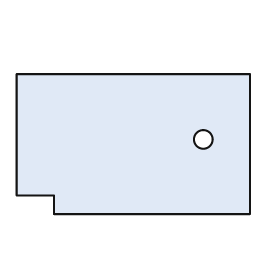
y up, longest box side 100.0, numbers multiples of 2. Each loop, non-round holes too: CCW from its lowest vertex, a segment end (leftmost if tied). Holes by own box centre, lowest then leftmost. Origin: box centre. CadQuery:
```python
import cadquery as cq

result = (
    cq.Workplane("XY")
    .moveTo(-34.0, -30.0)
    .lineTo(50.0, -30.0)
    .lineTo(50.0, 30.0)
    .lineTo(-50.0, 30.0)
    .lineTo(-50.0, -22.0)
    .lineTo(-34.0, -22.0)
    .close()
    .moveTo(30.0, 2.0)
    .circle(4.0)
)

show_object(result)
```